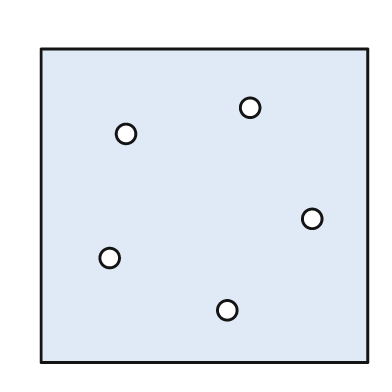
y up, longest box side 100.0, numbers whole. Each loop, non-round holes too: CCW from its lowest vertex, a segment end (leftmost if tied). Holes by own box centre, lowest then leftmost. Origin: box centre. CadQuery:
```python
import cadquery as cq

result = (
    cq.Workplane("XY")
    .moveTo(-50.0, -48.0)
    .lineTo(50.0, -48.0)
    .lineTo(50.0, 48.0)
    .lineTo(-50.0, 48.0)
    .close()
    .moveTo(7.0, -32.0)
    .circle(3.0)
    .moveTo(-29.0, -16.0)
    .circle(3.0)
    .moveTo(33.0, -4.0)
    .circle(3.0)
    .moveTo(-24.0, 22.0)
    .circle(3.0)
    .moveTo(14.0, 30.0)
    .circle(3.0)
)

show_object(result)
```